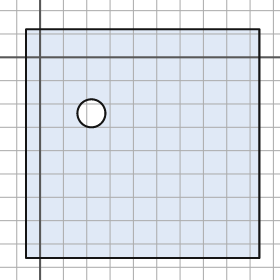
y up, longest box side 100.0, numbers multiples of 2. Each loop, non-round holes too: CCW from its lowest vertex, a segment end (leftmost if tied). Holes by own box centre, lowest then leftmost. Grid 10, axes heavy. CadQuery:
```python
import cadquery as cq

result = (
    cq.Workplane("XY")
    .moveTo(-6.0, -86.0)
    .lineTo(94.0, -86.0)
    .lineTo(94.0, 12.0)
    .lineTo(-6.0, 12.0)
    .close()
    .moveTo(22.0, -24.0)
    .circle(6.0)
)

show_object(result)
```